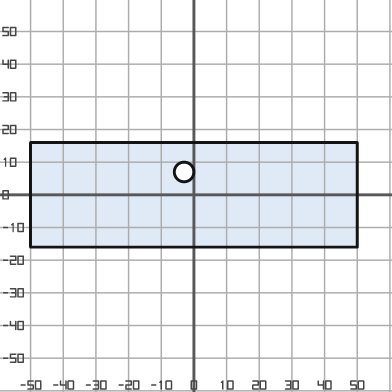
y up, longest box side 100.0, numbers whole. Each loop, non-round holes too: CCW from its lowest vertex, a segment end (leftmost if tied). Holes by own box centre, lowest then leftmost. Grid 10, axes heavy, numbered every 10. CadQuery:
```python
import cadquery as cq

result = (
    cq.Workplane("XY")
    .moveTo(-50.0, -16.0)
    .lineTo(50.0, -16.0)
    .lineTo(50.0, 16.0)
    .lineTo(-50.0, 16.0)
    .close()
    .moveTo(-3.0, 7.0)
    .circle(3.0)
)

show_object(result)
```